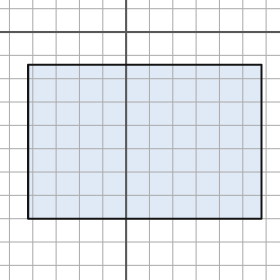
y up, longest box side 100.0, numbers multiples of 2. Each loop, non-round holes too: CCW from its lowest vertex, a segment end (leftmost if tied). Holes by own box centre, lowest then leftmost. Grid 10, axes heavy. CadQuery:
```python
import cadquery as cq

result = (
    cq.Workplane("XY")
    .moveTo(-42.0, -80.0)
    .lineTo(58.0, -80.0)
    .lineTo(58.0, -14.0)
    .lineTo(-42.0, -14.0)
    .close()
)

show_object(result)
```